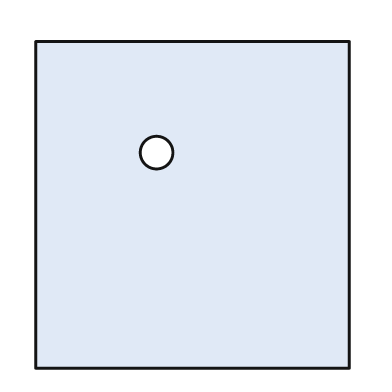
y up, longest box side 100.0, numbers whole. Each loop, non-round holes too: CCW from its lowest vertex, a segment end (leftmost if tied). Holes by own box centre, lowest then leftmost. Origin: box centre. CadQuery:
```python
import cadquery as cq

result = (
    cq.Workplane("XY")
    .moveTo(-48.0, -50.0)
    .lineTo(48.0, -50.0)
    .lineTo(48.0, 50.0)
    .lineTo(-48.0, 50.0)
    .close()
    .moveTo(-11.0, 16.0)
    .circle(5.0)
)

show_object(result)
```